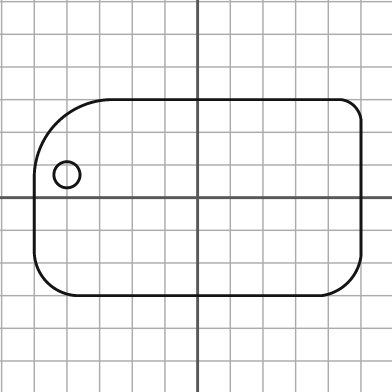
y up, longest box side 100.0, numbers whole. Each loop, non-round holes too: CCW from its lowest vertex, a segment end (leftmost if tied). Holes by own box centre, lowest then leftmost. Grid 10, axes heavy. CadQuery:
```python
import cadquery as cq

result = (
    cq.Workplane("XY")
    .moveTo(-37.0, -30.0)
    .lineTo(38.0, -30.0)
    .threePointArc((46.0, -26.0), (50.0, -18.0))
    .lineTo(50.0, 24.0)
    .threePointArc((48.0, 28.0), (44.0, 30.0))
    .lineTo(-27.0, 30.0)
    .threePointArc((-43.0, 23.0), (-50.0, 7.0))
    .lineTo(-50.0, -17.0)
    .threePointArc((-46.0, -26.0), (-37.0, -30.0))
    .close()
    .moveTo(-40.0, 7.0)
    .circle(4.0)
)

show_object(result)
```